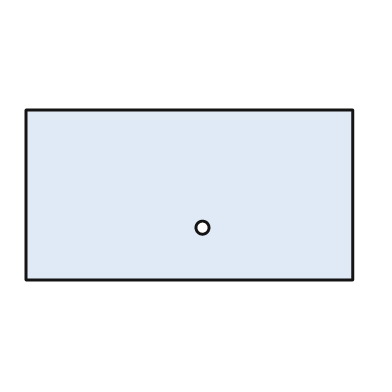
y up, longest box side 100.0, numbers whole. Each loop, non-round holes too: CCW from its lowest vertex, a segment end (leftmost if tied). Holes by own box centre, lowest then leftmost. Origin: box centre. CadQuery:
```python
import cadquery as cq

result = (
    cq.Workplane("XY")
    .moveTo(-50.0, -26.0)
    .lineTo(50.0, -26.0)
    .lineTo(50.0, 26.0)
    .lineTo(-50.0, 26.0)
    .close()
    .moveTo(4.0, -10.0)
    .circle(2.0)
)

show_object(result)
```